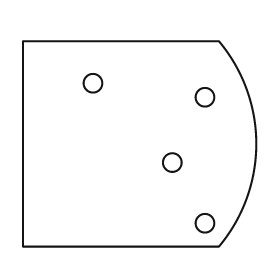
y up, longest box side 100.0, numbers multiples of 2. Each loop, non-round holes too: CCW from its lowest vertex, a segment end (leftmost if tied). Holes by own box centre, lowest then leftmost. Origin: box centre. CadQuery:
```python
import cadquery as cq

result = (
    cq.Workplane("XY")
    .moveTo(-50.0, -44.0)
    .lineTo(34.0, -44.0)
    .threePointArc((50.0, 0.0), (34.0, 44.0))
    .lineTo(-50.0, 44.0)
    .close()
    .moveTo(28.0, -34.0)
    .circle(4.0)
    .moveTo(14.0, -8.0)
    .circle(4.0)
    .moveTo(28.0, 20.0)
    .circle(4.0)
    .moveTo(-20.0, 26.0)
    .circle(4.0)
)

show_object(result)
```